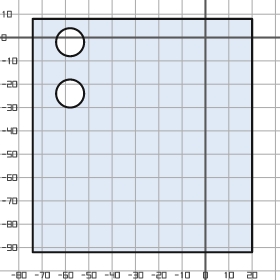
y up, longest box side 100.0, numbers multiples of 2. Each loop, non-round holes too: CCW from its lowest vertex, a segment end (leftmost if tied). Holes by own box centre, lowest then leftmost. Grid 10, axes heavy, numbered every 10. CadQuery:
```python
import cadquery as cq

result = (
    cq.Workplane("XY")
    .moveTo(-74.0, -92.0)
    .lineTo(20.0, -92.0)
    .lineTo(20.0, 8.0)
    .lineTo(-74.0, 8.0)
    .close()
    .moveTo(-58.0, -24.0)
    .circle(6.0)
    .moveTo(-58.0, -2.0)
    .circle(6.0)
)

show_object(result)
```